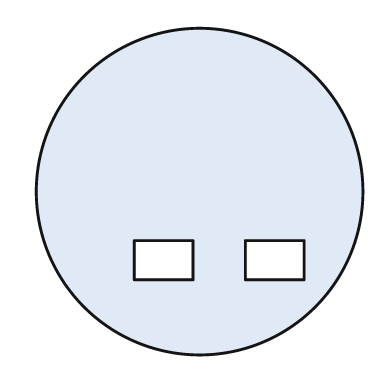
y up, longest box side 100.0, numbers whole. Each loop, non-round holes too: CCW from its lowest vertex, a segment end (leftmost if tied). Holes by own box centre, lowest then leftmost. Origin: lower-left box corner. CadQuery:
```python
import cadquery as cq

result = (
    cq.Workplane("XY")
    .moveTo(50.0, 50.0)
    .circle(50.0)
    .moveTo(30.0, 23.0)
    .lineTo(48.0, 23.0)
    .lineTo(48.0, 35.0)
    .lineTo(30.0, 35.0)
    .close()
    .moveTo(64.0, 23.0)
    .lineTo(82.0, 23.0)
    .lineTo(82.0, 35.0)
    .lineTo(64.0, 35.0)
    .close()
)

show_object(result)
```